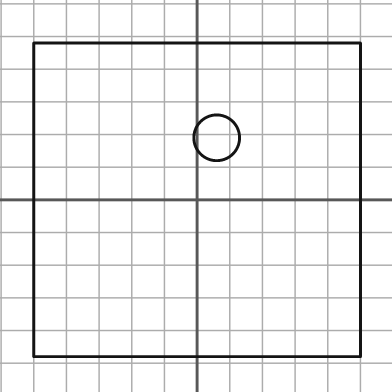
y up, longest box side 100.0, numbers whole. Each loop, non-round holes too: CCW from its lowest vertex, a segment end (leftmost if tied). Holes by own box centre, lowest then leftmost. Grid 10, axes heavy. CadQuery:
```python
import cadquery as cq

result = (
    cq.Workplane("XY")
    .moveTo(-50.0, -48.0)
    .lineTo(50.0, -48.0)
    .lineTo(50.0, 48.0)
    .lineTo(-50.0, 48.0)
    .close()
    .moveTo(6.0, 19.0)
    .circle(7.0)
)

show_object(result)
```